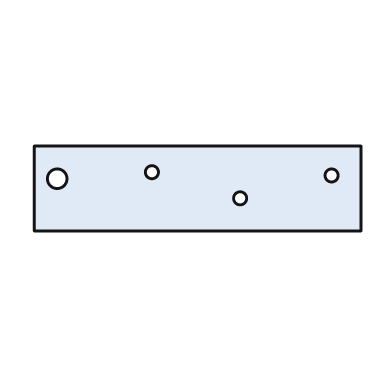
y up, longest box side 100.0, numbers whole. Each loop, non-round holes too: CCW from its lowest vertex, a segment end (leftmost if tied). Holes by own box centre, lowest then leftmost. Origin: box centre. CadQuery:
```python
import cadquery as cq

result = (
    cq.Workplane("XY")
    .moveTo(-50.0, -13.0)
    .lineTo(50.0, -13.0)
    .lineTo(50.0, 13.0)
    .lineTo(-50.0, 13.0)
    .close()
    .moveTo(13.0, -3.0)
    .circle(2.0)
    .moveTo(-43.0, 3.0)
    .circle(3.0)
    .moveTo(41.0, 4.0)
    .circle(2.0)
    .moveTo(-14.0, 5.0)
    .circle(2.0)
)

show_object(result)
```